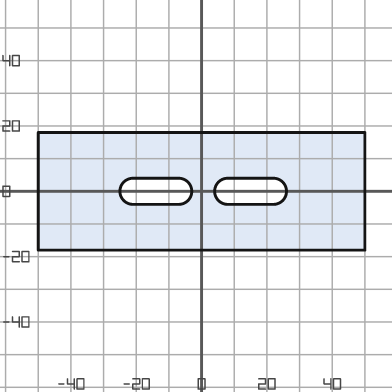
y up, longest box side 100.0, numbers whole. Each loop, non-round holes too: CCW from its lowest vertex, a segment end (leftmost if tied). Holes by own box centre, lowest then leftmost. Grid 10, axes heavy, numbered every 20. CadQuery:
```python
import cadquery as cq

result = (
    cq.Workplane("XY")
    .moveTo(-50.0, -18.0)
    .lineTo(50.0, -18.0)
    .lineTo(50.0, 18.0)
    .lineTo(-50.0, 18.0)
    .close()
    .moveTo(-21.0, -4.0)
    .lineTo(-7.0, -4.0)
    .threePointArc((-3.0, 0.0), (-7.0, 4.0))
    .lineTo(-21.0, 4.0)
    .threePointArc((-25.0, 0.0), (-21.0, -4.0))
    .close()
    .moveTo(8.0, -4.0)
    .lineTo(22.0, -4.0)
    .threePointArc((26.0, 0.0), (22.0, 4.0))
    .lineTo(8.0, 4.0)
    .threePointArc((4.0, 0.0), (8.0, -4.0))
    .close()
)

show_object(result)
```